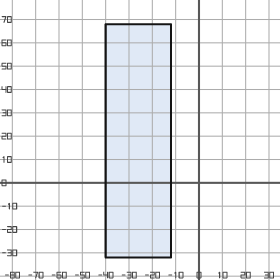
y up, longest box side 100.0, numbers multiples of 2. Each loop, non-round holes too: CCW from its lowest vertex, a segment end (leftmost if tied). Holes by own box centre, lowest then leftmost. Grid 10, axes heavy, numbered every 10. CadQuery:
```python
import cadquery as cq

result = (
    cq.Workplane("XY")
    .moveTo(-40.0, -32.0)
    .lineTo(-12.0, -32.0)
    .lineTo(-12.0, 68.0)
    .lineTo(-40.0, 68.0)
    .close()
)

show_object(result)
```